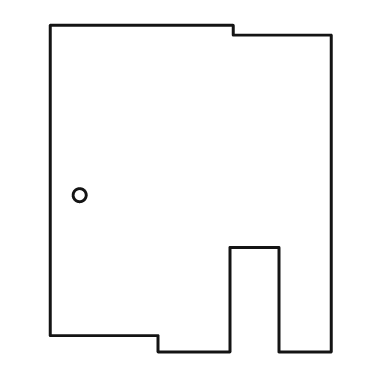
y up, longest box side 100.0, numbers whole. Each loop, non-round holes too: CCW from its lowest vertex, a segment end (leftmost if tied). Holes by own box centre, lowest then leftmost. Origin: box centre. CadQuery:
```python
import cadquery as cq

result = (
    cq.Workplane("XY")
    .moveTo(-10.0, -50.0)
    .lineTo(12.0, -50.0)
    .lineTo(12.0, -18.0)
    .lineTo(27.0, -18.0)
    .lineTo(27.0, -50.0)
    .lineTo(43.0, -50.0)
    .lineTo(43.0, 47.0)
    .lineTo(13.0, 47.0)
    .lineTo(13.0, 50.0)
    .lineTo(-43.0, 50.0)
    .lineTo(-43.0, -45.0)
    .lineTo(-10.0, -45.0)
    .close()
    .moveTo(-34.0, -2.0)
    .circle(2.0)
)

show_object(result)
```